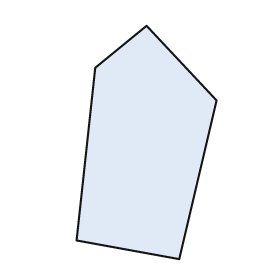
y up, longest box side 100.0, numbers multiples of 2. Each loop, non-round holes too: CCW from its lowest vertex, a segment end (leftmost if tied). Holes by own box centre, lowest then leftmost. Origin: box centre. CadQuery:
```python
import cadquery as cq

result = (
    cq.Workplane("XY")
    .moveTo(14.0, -50.0)
    .lineTo(30.0, 18.0)
    .lineTo(0.0, 50.0)
    .lineTo(-22.0, 32.0)
    .lineTo(-30.0, -42.0)
    .close()
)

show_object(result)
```